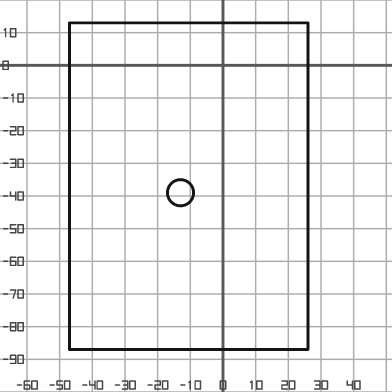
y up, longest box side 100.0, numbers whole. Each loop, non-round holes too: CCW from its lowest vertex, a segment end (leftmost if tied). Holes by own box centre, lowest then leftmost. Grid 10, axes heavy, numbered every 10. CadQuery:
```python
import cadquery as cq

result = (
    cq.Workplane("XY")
    .moveTo(-47.0, -87.0)
    .lineTo(26.0, -87.0)
    .lineTo(26.0, 13.0)
    .lineTo(-47.0, 13.0)
    .close()
    .moveTo(-13.0, -39.0)
    .circle(4.0)
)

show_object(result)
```